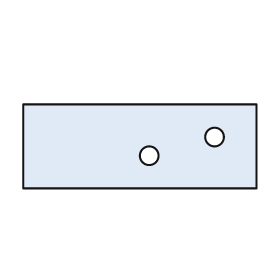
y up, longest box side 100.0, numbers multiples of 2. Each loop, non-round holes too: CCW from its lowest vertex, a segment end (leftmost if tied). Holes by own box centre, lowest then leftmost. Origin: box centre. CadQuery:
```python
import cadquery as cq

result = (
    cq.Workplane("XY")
    .moveTo(-50.0, -18.0)
    .lineTo(50.0, -18.0)
    .lineTo(50.0, 18.0)
    .lineTo(-50.0, 18.0)
    .close()
    .moveTo(4.0, -4.0)
    .circle(4.0)
    .moveTo(32.0, 4.0)
    .circle(4.0)
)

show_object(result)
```